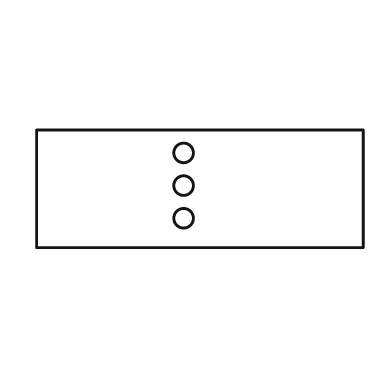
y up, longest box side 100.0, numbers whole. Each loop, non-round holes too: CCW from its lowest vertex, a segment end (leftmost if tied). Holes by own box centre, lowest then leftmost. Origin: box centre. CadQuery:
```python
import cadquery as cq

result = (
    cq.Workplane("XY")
    .moveTo(-50.0, -18.0)
    .lineTo(50.0, -18.0)
    .lineTo(50.0, 18.0)
    .lineTo(-50.0, 18.0)
    .close()
    .moveTo(-5.0, -9.0)
    .circle(3.0)
    .moveTo(-5.0, 1.0)
    .circle(3.0)
    .moveTo(-5.0, 11.0)
    .circle(3.0)
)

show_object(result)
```